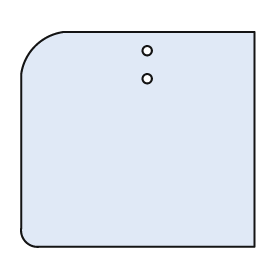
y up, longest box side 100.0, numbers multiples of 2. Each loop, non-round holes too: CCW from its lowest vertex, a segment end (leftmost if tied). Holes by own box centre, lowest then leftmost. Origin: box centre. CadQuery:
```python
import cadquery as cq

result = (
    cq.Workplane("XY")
    .moveTo(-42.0, -46.0)
    .lineTo(50.0, -46.0)
    .lineTo(50.0, 46.0)
    .lineTo(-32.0, 46.0)
    .threePointArc((-44.0, 40.0), (-50.0, 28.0))
    .lineTo(-50.0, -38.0)
    .threePointArc((-48.0, -44.0), (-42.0, -46.0))
    .close()
    .moveTo(4.0, 26.0)
    .circle(2.0)
    .moveTo(4.0, 38.0)
    .circle(2.0)
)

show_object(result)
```